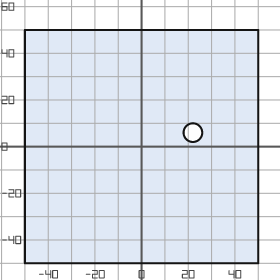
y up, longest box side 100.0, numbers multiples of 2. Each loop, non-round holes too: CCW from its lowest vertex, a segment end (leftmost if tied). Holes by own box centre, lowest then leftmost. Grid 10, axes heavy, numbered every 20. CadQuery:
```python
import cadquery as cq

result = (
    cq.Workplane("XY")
    .moveTo(-50.0, -50.0)
    .lineTo(50.0, -50.0)
    .lineTo(50.0, 50.0)
    .lineTo(-50.0, 50.0)
    .close()
    .moveTo(22.0, 6.0)
    .circle(4.0)
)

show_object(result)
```